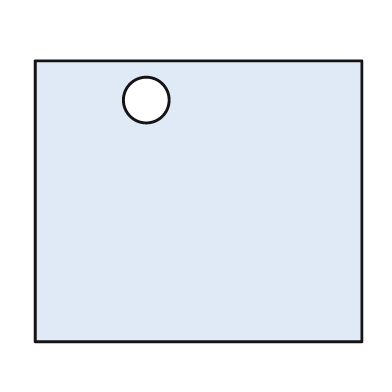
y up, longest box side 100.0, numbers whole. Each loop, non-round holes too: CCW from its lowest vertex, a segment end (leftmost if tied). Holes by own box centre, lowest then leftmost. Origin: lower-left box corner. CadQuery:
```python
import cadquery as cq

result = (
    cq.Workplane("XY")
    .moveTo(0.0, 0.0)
    .lineTo(100.0, 0.0)
    .lineTo(100.0, 86.0)
    .lineTo(0.0, 86.0)
    .close()
    .moveTo(34.0, 74.0)
    .circle(7.0)
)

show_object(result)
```